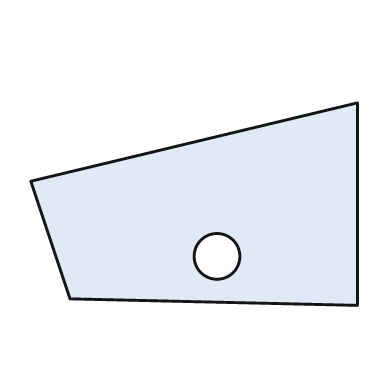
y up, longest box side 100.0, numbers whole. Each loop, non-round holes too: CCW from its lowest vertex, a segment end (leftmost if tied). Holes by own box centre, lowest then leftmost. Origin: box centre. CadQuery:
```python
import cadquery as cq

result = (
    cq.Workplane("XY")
    .moveTo(50.0, -31.0)
    .lineTo(50.0, 31.0)
    .lineTo(-50.0, 7.0)
    .lineTo(-38.0, -29.0)
    .close()
    .moveTo(7.0, -16.0)
    .circle(7.0)
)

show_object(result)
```